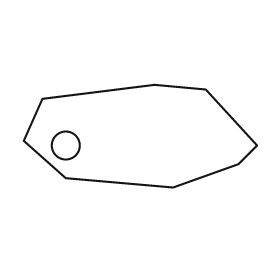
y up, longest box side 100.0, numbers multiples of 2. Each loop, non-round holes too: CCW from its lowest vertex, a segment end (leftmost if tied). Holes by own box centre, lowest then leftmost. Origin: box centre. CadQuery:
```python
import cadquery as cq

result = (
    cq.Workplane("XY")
    .moveTo(14.0, -22.0)
    .lineTo(42.0, -12.0)
    .lineTo(50.0, -4.0)
    .lineTo(28.0, 20.0)
    .lineTo(6.0, 22.0)
    .lineTo(-42.0, 16.0)
    .lineTo(-50.0, -2.0)
    .lineTo(-32.0, -18.0)
    .close()
    .moveTo(-32.0, -4.0)
    .circle(6.0)
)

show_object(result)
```